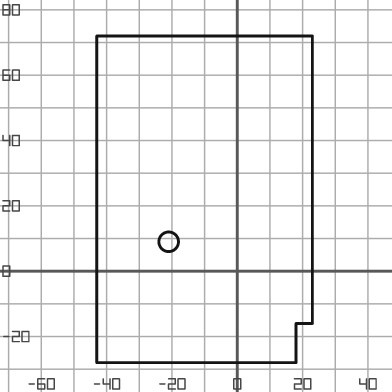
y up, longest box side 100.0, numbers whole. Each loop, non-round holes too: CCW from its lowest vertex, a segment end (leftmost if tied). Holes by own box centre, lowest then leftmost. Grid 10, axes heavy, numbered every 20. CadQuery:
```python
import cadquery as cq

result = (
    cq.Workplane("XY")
    .moveTo(-43.0, -28.0)
    .lineTo(18.0, -28.0)
    .lineTo(18.0, -16.0)
    .lineTo(23.0, -16.0)
    .lineTo(23.0, 72.0)
    .lineTo(-43.0, 72.0)
    .close()
    .moveTo(-21.0, 9.0)
    .circle(3.0)
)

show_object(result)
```